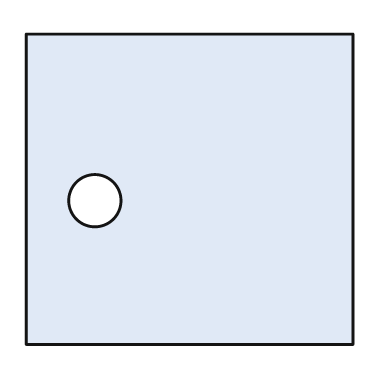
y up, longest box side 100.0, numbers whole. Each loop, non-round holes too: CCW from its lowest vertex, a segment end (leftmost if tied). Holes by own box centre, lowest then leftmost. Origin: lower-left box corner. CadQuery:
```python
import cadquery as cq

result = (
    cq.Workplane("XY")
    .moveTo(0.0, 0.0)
    .lineTo(100.0, 0.0)
    .lineTo(100.0, 95.0)
    .lineTo(0.0, 95.0)
    .close()
    .moveTo(21.0, 44.0)
    .circle(8.0)
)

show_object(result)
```